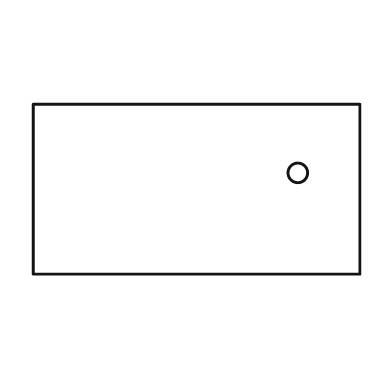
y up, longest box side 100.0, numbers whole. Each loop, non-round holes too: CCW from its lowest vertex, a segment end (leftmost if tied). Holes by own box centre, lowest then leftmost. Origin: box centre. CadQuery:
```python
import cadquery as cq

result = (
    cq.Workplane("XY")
    .moveTo(-50.0, -26.0)
    .lineTo(50.0, -26.0)
    .lineTo(50.0, 26.0)
    .lineTo(-50.0, 26.0)
    .close()
    .moveTo(31.0, 5.0)
    .circle(3.0)
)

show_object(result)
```